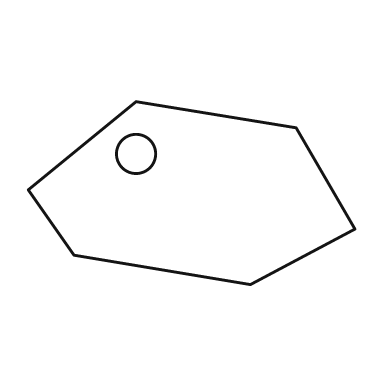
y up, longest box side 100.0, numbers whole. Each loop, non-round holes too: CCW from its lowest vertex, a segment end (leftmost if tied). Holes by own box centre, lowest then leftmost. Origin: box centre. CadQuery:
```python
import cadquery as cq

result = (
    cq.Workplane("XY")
    .moveTo(18.0, -28.0)
    .lineTo(50.0, -11.0)
    .lineTo(32.0, 20.0)
    .lineTo(-17.0, 28.0)
    .lineTo(-50.0, 1.0)
    .lineTo(-36.0, -19.0)
    .close()
    .moveTo(-17.0, 12.0)
    .circle(6.0)
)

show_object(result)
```